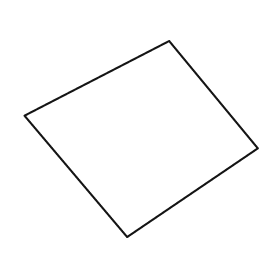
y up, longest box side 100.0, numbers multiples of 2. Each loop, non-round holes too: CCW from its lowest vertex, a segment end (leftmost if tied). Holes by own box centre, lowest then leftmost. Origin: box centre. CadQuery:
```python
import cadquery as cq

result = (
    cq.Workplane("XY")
    .moveTo(-6.0, -42.0)
    .lineTo(50.0, -4.0)
    .lineTo(12.0, 42.0)
    .lineTo(-50.0, 10.0)
    .close()
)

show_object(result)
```